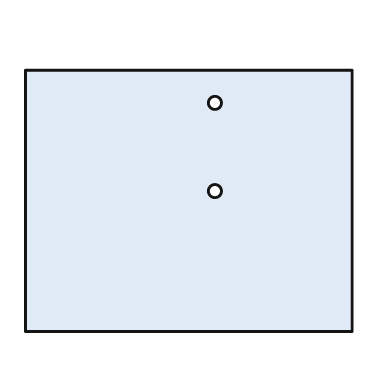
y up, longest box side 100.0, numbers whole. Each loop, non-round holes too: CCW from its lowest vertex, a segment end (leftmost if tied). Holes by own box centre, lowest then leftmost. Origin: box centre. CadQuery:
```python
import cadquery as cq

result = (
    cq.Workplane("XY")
    .moveTo(-50.0, -40.0)
    .lineTo(50.0, -40.0)
    .lineTo(50.0, 40.0)
    .lineTo(-50.0, 40.0)
    .close()
    .moveTo(8.0, 3.0)
    .circle(2.0)
    .moveTo(8.0, 30.0)
    .circle(2.0)
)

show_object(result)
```